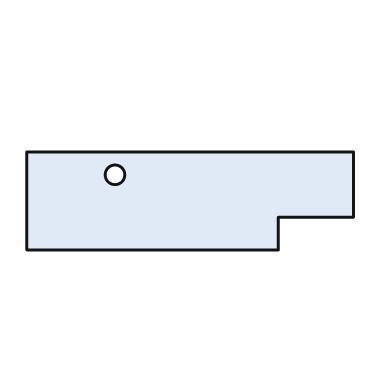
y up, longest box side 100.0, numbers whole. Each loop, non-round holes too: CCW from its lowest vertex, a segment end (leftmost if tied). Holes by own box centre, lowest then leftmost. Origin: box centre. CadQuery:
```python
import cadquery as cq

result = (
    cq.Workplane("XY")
    .moveTo(-50.0, -15.0)
    .lineTo(27.0, -15.0)
    .lineTo(27.0, -5.0)
    .lineTo(50.0, -5.0)
    .lineTo(50.0, 15.0)
    .lineTo(-50.0, 15.0)
    .close()
    .moveTo(-23.0, 8.0)
    .circle(3.0)
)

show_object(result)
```